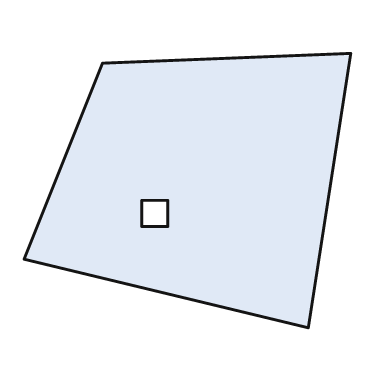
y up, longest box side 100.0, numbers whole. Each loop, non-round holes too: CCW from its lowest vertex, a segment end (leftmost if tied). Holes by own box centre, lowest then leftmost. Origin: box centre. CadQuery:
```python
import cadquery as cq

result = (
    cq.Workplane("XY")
    .moveTo(37.0, -42.0)
    .lineTo(50.0, 42.0)
    .lineTo(-26.0, 39.0)
    .lineTo(-50.0, -21.0)
    .close()
    .moveTo(-14.0, -11.0)
    .lineTo(-6.0, -11.0)
    .lineTo(-6.0, -3.0)
    .lineTo(-14.0, -3.0)
    .close()
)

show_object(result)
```